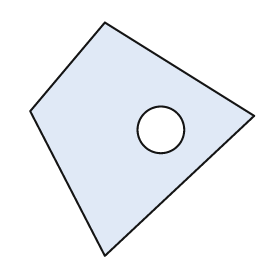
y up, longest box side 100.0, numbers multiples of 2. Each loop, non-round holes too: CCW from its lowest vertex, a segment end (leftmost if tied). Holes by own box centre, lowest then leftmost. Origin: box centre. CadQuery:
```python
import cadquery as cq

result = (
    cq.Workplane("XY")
    .moveTo(-16.0, -50.0)
    .lineTo(48.0, 10.0)
    .lineTo(-16.0, 50.0)
    .lineTo(-48.0, 12.0)
    .close()
    .moveTo(8.0, 4.0)
    .circle(10.0)
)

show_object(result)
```